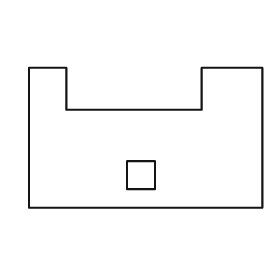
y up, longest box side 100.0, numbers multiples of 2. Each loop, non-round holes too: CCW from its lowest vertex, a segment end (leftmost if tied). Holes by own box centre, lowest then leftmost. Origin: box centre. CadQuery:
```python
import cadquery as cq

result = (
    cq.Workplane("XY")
    .moveTo(-50.0, -30.0)
    .lineTo(50.0, -30.0)
    .lineTo(50.0, 30.0)
    .lineTo(24.0, 30.0)
    .lineTo(24.0, 12.0)
    .lineTo(-34.0, 12.0)
    .lineTo(-34.0, 30.0)
    .lineTo(-50.0, 30.0)
    .close()
    .moveTo(-8.0, -22.0)
    .lineTo(4.0, -22.0)
    .lineTo(4.0, -10.0)
    .lineTo(-8.0, -10.0)
    .close()
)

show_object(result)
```